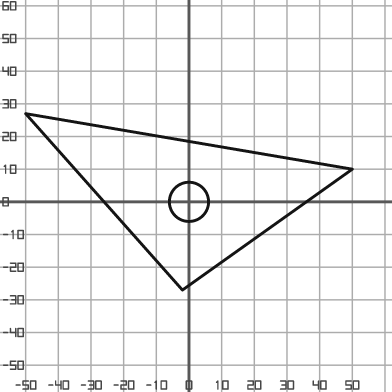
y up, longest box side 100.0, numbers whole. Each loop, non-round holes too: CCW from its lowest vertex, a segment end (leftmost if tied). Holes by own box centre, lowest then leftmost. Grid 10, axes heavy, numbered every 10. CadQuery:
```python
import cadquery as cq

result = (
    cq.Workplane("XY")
    .moveTo(-2.0, -27.0)
    .lineTo(50.0, 10.0)
    .lineTo(-50.0, 27.0)
    .close()
    .moveTo(0.0, 0.0)
    .circle(6.0)
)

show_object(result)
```